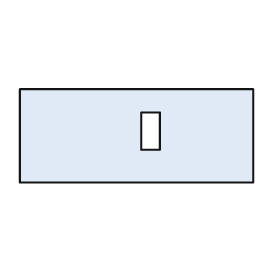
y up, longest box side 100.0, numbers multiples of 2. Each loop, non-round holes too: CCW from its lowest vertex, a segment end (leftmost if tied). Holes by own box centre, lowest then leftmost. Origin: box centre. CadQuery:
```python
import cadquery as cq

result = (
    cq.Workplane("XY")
    .moveTo(-50.0, -20.0)
    .lineTo(50.0, -20.0)
    .lineTo(50.0, 20.0)
    .lineTo(-50.0, 20.0)
    .close()
    .moveTo(2.0, -6.0)
    .lineTo(10.0, -6.0)
    .lineTo(10.0, 10.0)
    .lineTo(2.0, 10.0)
    .close()
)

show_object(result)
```